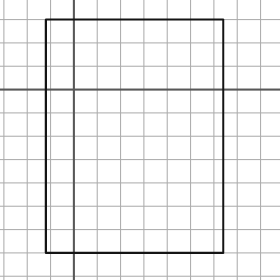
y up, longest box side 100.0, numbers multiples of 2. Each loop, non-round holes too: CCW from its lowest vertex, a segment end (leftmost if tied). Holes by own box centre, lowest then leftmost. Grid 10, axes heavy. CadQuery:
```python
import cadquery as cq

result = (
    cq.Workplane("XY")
    .moveTo(-12.0, -70.0)
    .lineTo(64.0, -70.0)
    .lineTo(64.0, 30.0)
    .lineTo(-12.0, 30.0)
    .close()
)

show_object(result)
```